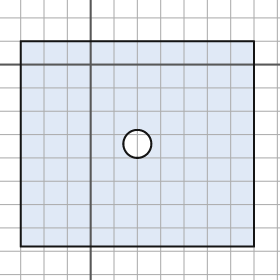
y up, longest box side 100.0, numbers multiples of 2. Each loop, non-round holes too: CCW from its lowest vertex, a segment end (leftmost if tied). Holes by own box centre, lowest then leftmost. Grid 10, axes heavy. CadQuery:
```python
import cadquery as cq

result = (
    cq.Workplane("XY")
    .moveTo(-30.0, -78.0)
    .lineTo(70.0, -78.0)
    .lineTo(70.0, 10.0)
    .lineTo(-30.0, 10.0)
    .close()
    .moveTo(20.0, -34.0)
    .circle(6.0)
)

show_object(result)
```